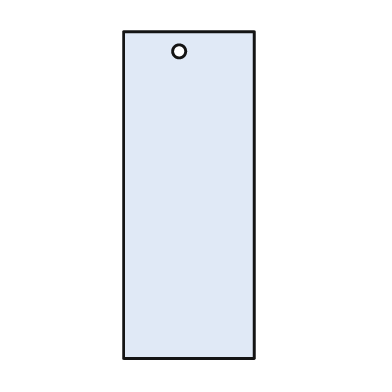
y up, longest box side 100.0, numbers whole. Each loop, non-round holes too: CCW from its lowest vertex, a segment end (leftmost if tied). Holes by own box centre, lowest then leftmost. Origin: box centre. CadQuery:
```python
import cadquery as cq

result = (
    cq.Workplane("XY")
    .moveTo(-20.0, -50.0)
    .lineTo(20.0, -50.0)
    .lineTo(20.0, 50.0)
    .lineTo(-20.0, 50.0)
    .close()
    .moveTo(-3.0, 44.0)
    .circle(2.0)
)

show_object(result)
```